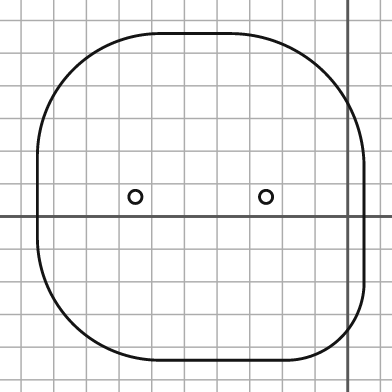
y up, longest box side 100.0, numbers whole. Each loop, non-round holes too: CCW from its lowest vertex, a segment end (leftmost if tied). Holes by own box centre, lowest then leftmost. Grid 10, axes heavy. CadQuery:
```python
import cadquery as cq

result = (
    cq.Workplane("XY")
    .moveTo(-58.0, -44.0)
    .lineTo(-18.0, -44.0)
    .threePointArc((-2.0, -37.0), (5.0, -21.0))
    .lineTo(5.0, 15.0)
    .threePointArc((-7.0, 44.0), (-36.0, 56.0))
    .lineTo(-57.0, 56.0)
    .threePointArc((-84.0, 45.0), (-95.0, 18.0))
    .lineTo(-95.0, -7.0)
    .threePointArc((-84.0, -33.0), (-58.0, -44.0))
    .close()
    .moveTo(-65.0, 6.0)
    .circle(2.0)
    .moveTo(-25.0, 6.0)
    .circle(2.0)
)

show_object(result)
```